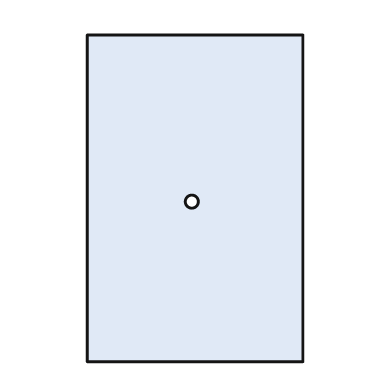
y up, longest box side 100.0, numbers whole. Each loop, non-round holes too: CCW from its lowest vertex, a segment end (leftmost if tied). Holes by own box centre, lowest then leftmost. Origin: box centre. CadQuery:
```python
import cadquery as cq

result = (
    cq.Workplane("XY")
    .moveTo(-33.0, -50.0)
    .lineTo(33.0, -50.0)
    .lineTo(33.0, 50.0)
    .lineTo(-33.0, 50.0)
    .close()
    .moveTo(-1.0, -1.0)
    .circle(2.0)
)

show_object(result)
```